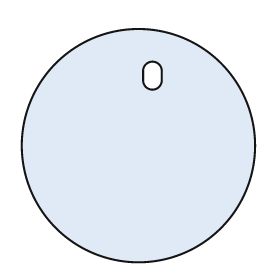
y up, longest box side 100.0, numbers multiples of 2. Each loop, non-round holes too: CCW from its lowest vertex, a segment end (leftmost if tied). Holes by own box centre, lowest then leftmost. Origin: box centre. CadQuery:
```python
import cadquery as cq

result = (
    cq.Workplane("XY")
    .moveTo(0.0, 0.0)
    .circle(50.0)
    .moveTo(2.0, 28.0)
    .threePointArc((6.0, 24.0), (10.0, 28.0))
    .lineTo(10.0, 32.0)
    .threePointArc((6.0, 36.0), (2.0, 32.0))
    .close()
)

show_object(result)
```